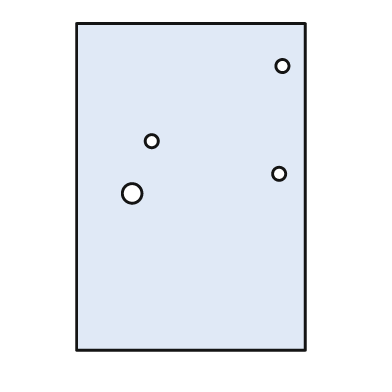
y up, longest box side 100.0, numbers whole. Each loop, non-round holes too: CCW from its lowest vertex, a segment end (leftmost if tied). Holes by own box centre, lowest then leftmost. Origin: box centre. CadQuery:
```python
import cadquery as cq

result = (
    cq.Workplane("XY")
    .moveTo(-35.0, -50.0)
    .lineTo(35.0, -50.0)
    .lineTo(35.0, 50.0)
    .lineTo(-35.0, 50.0)
    .close()
    .moveTo(-18.0, -2.0)
    .circle(3.0)
    .moveTo(27.0, 4.0)
    .circle(2.0)
    .moveTo(-12.0, 14.0)
    .circle(2.0)
    .moveTo(28.0, 37.0)
    .circle(2.0)
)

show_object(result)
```